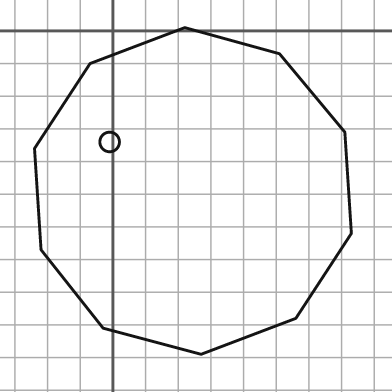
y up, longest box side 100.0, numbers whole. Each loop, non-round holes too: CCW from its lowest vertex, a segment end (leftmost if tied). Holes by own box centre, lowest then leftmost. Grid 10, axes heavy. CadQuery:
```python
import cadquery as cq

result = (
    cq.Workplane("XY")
    .moveTo(27.0, -99.0)
    .lineTo(56.0, -88.0)
    .lineTo(73.0, -62.0)
    .lineTo(71.0, -31.0)
    .lineTo(51.0, -7.0)
    .lineTo(22.0, 1.0)
    .lineTo(-7.0, -10.0)
    .lineTo(-24.0, -36.0)
    .lineTo(-22.0, -67.0)
    .lineTo(-3.0, -91.0)
    .close()
    .moveTo(-1.0, -34.0)
    .circle(3.0)
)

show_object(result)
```